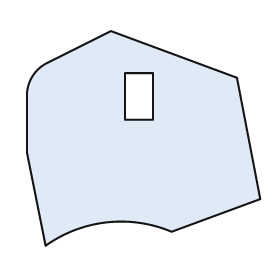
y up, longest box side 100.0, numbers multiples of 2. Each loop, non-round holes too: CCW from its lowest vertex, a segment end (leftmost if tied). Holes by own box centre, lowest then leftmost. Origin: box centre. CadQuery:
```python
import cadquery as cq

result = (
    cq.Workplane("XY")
    .moveTo(-42.0, -46.0)
    .threePointArc((-16.0, -36.0), (12.0, -40.0))
    .lineTo(50.0, -26.0)
    .lineTo(40.0, 26.0)
    .lineTo(-14.0, 46.0)
    .lineTo(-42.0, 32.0)
    .threePointArc((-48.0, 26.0), (-50.0, 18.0))
    .lineTo(-50.0, -6.0)
    .close()
    .moveTo(-8.0, 8.0)
    .lineTo(4.0, 8.0)
    .lineTo(4.0, 28.0)
    .lineTo(-8.0, 28.0)
    .close()
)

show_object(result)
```